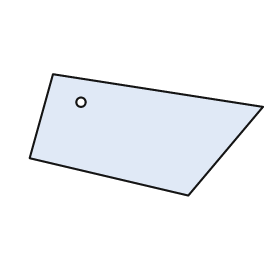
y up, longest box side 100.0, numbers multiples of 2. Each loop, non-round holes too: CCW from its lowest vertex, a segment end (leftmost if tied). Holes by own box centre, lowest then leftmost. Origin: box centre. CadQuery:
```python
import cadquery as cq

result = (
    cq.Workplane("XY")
    .moveTo(18.0, -26.0)
    .lineTo(50.0, 12.0)
    .lineTo(-40.0, 26.0)
    .lineTo(-50.0, -10.0)
    .close()
    .moveTo(-28.0, 14.0)
    .circle(2.0)
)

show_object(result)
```